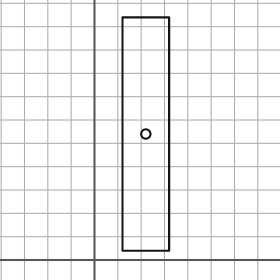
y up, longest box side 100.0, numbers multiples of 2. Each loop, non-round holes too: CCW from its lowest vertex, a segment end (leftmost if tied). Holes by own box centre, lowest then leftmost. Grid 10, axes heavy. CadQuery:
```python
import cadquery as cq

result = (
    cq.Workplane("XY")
    .moveTo(12.0, 4.0)
    .lineTo(32.0, 4.0)
    .lineTo(32.0, 104.0)
    .lineTo(12.0, 104.0)
    .close()
    .moveTo(22.0, 54.0)
    .circle(2.0)
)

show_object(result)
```